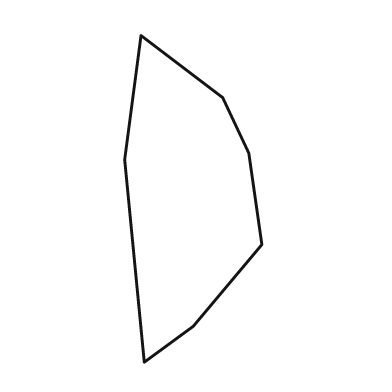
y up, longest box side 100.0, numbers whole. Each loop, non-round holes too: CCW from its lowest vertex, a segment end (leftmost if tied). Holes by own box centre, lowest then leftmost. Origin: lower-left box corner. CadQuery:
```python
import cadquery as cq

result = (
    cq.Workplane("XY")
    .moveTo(6.0, 0.0)
    .lineTo(21.0, 11.0)
    .lineTo(42.0, 36.0)
    .lineTo(38.0, 64.0)
    .lineTo(30.0, 81.0)
    .lineTo(5.0, 100.0)
    .lineTo(0.0, 62.0)
    .close()
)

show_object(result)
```